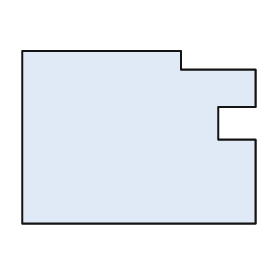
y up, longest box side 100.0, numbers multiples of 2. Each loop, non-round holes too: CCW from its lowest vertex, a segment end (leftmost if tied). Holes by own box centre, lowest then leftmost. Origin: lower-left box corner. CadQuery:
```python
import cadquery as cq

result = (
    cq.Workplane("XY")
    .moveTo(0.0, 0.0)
    .lineTo(100.0, 0.0)
    .lineTo(100.0, 36.0)
    .lineTo(84.0, 36.0)
    .lineTo(84.0, 50.0)
    .lineTo(100.0, 50.0)
    .lineTo(100.0, 66.0)
    .lineTo(68.0, 66.0)
    .lineTo(68.0, 74.0)
    .lineTo(0.0, 74.0)
    .close()
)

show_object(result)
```